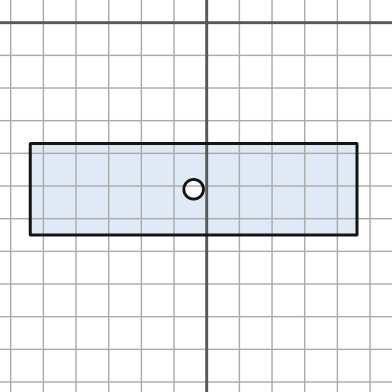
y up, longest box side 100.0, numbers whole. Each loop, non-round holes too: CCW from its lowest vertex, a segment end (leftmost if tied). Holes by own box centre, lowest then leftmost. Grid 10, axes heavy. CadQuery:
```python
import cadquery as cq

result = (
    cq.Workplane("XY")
    .moveTo(-54.0, -65.0)
    .lineTo(46.0, -65.0)
    .lineTo(46.0, -37.0)
    .lineTo(-54.0, -37.0)
    .close()
    .moveTo(-4.0, -51.0)
    .circle(3.0)
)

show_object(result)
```